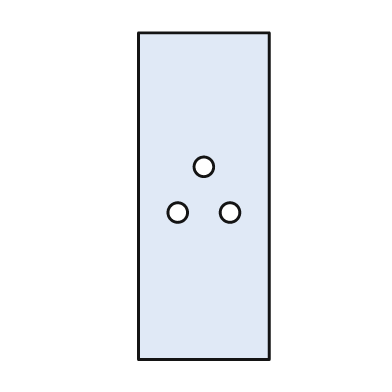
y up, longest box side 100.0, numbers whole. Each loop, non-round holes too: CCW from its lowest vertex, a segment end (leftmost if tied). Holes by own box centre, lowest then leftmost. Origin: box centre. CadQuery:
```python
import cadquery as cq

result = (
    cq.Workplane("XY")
    .moveTo(-20.0, -50.0)
    .lineTo(20.0, -50.0)
    .lineTo(20.0, 50.0)
    .lineTo(-20.0, 50.0)
    .close()
    .moveTo(-8.0, -5.0)
    .circle(3.0)
    .moveTo(8.0, -5.0)
    .circle(3.0)
    .moveTo(0.0, 9.0)
    .circle(3.0)
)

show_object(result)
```